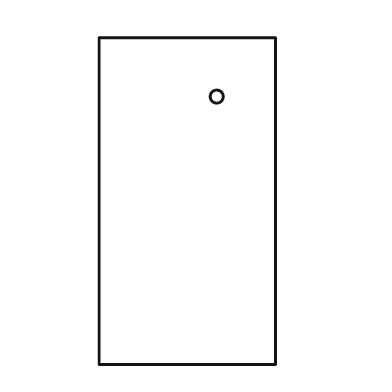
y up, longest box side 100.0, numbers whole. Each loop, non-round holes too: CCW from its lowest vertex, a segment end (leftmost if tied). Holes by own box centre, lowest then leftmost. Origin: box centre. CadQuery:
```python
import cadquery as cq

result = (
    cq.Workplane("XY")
    .moveTo(-27.0, -50.0)
    .lineTo(27.0, -50.0)
    .lineTo(27.0, 50.0)
    .lineTo(-27.0, 50.0)
    .close()
    .moveTo(9.0, 32.0)
    .circle(2.0)
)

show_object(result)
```